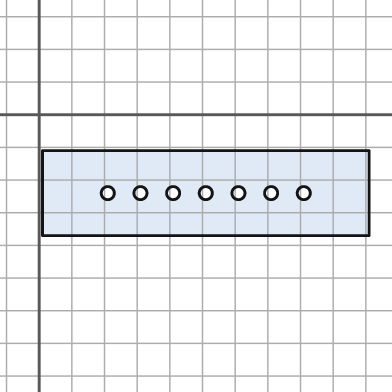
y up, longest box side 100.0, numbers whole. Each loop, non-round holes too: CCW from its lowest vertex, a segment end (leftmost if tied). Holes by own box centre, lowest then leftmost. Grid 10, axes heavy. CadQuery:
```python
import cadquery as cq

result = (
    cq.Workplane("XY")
    .moveTo(1.0, -37.0)
    .lineTo(101.0, -37.0)
    .lineTo(101.0, -11.0)
    .lineTo(1.0, -11.0)
    .close()
    .moveTo(21.0, -24.0)
    .circle(2.0)
    .moveTo(31.0, -24.0)
    .circle(2.0)
    .moveTo(41.0, -24.0)
    .circle(2.0)
    .moveTo(51.0, -24.0)
    .circle(2.0)
    .moveTo(61.0, -24.0)
    .circle(2.0)
    .moveTo(71.0, -24.0)
    .circle(2.0)
    .moveTo(81.0, -24.0)
    .circle(2.0)
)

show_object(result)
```